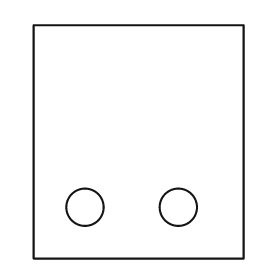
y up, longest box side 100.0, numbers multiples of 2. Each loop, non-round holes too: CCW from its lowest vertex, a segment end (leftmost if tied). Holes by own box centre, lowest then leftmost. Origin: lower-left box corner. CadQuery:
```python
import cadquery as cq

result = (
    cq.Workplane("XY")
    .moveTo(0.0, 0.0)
    .lineTo(90.0, 0.0)
    .lineTo(90.0, 100.0)
    .lineTo(0.0, 100.0)
    .close()
    .moveTo(22.0, 22.0)
    .circle(8.0)
    .moveTo(62.0, 22.0)
    .circle(8.0)
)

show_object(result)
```